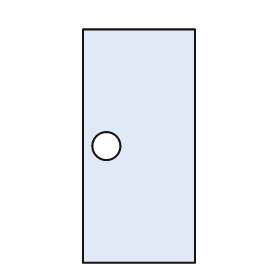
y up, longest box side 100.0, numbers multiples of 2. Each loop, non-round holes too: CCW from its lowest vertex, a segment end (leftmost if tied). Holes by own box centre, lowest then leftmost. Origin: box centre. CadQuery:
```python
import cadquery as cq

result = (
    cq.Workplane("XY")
    .moveTo(-24.0, -50.0)
    .lineTo(24.0, -50.0)
    .lineTo(24.0, 50.0)
    .lineTo(-24.0, 50.0)
    .close()
    .moveTo(-14.0, 0.0)
    .circle(6.0)
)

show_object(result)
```